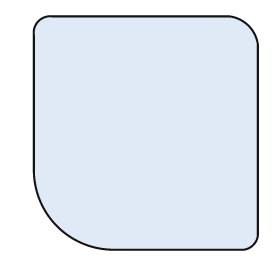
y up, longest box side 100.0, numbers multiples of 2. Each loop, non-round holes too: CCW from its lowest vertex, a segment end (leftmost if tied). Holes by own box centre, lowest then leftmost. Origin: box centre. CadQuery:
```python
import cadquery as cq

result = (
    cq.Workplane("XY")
    .moveTo(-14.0, -50.0)
    .lineTo(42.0, -50.0)
    .threePointArc((46.0, -48.0), (48.0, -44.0))
    .lineTo(48.0, 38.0)
    .threePointArc((44.0, 46.0), (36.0, 50.0))
    .lineTo(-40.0, 50.0)
    .threePointArc((-46.0, 48.0), (-48.0, 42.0))
    .lineTo(-48.0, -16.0)
    .threePointArc((-38.0, -40.0), (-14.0, -50.0))
    .close()
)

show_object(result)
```